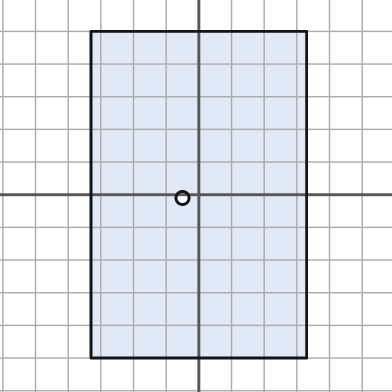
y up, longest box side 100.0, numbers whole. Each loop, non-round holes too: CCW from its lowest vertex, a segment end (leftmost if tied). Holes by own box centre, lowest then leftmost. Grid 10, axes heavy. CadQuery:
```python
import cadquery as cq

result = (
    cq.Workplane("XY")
    .moveTo(-33.0, -50.0)
    .lineTo(33.0, -50.0)
    .lineTo(33.0, 50.0)
    .lineTo(-33.0, 50.0)
    .close()
    .moveTo(-5.0, -1.0)
    .circle(2.0)
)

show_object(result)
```